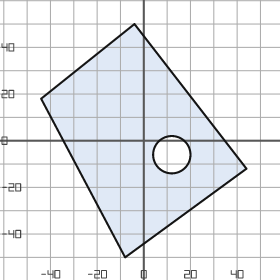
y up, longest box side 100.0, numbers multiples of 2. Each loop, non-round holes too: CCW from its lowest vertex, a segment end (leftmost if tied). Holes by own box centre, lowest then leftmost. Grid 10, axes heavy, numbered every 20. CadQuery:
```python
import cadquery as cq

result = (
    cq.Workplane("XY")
    .moveTo(-8.0, -50.0)
    .lineTo(44.0, -12.0)
    .lineTo(-4.0, 50.0)
    .lineTo(-44.0, 18.0)
    .close()
    .moveTo(12.0, -6.0)
    .circle(8.0)
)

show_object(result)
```